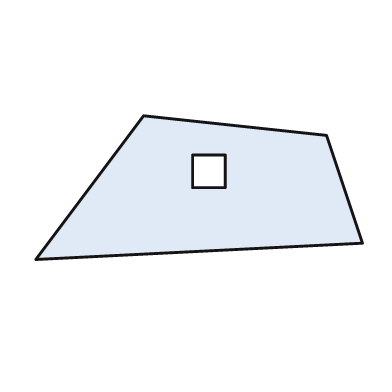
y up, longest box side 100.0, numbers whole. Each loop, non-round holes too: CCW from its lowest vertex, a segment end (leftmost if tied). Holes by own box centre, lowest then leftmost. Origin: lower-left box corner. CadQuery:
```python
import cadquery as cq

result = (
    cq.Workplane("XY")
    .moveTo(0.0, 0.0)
    .lineTo(100.0, 5.0)
    .lineTo(89.0, 38.0)
    .lineTo(33.0, 44.0)
    .close()
    .moveTo(48.0, 22.0)
    .lineTo(58.0, 22.0)
    .lineTo(58.0, 32.0)
    .lineTo(48.0, 32.0)
    .close()
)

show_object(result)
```